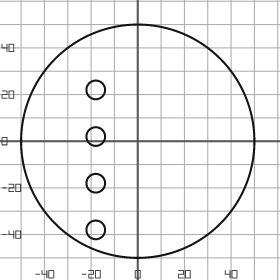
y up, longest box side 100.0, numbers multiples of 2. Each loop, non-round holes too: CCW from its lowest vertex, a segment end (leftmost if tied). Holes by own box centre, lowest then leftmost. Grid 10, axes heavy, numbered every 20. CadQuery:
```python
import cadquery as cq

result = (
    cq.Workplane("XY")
    .moveTo(0.0, 0.0)
    .circle(50.0)
    .moveTo(-18.0, -38.0)
    .circle(4.0)
    .moveTo(-18.0, -18.0)
    .circle(4.0)
    .moveTo(-18.0, 2.0)
    .circle(4.0)
    .moveTo(-18.0, 22.0)
    .circle(4.0)
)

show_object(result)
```